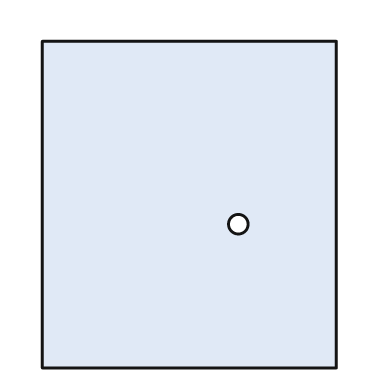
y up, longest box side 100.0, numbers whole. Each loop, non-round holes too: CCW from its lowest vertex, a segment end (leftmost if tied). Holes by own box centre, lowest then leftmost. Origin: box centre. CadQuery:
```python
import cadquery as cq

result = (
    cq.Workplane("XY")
    .moveTo(-45.0, -50.0)
    .lineTo(45.0, -50.0)
    .lineTo(45.0, 50.0)
    .lineTo(-45.0, 50.0)
    .close()
    .moveTo(15.0, -6.0)
    .circle(3.0)
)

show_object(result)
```